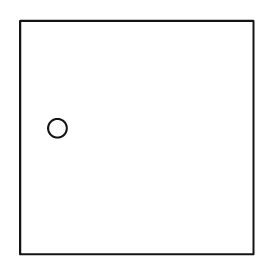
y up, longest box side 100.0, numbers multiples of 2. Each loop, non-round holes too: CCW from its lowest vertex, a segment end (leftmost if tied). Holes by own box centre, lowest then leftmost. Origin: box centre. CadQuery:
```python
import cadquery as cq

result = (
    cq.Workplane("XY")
    .moveTo(-50.0, -50.0)
    .lineTo(50.0, -50.0)
    .lineTo(50.0, 50.0)
    .lineTo(-50.0, 50.0)
    .close()
    .moveTo(-34.0, 4.0)
    .circle(4.0)
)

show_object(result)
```